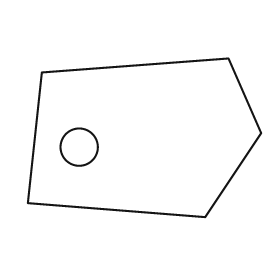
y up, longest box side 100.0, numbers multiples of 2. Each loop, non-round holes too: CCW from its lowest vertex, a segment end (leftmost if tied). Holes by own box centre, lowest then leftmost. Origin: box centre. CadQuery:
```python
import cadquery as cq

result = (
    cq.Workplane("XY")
    .moveTo(26.0, -34.0)
    .lineTo(50.0, 2.0)
    .lineTo(36.0, 34.0)
    .lineTo(-44.0, 28.0)
    .lineTo(-50.0, -28.0)
    .close()
    .moveTo(-28.0, -4.0)
    .circle(8.0)
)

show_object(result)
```